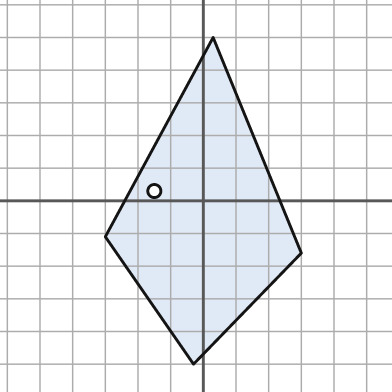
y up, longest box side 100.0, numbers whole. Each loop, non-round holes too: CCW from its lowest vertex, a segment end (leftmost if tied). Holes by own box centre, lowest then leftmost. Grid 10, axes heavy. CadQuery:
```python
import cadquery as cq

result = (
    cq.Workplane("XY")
    .moveTo(-3.0, -50.0)
    .lineTo(30.0, -16.0)
    .lineTo(3.0, 50.0)
    .lineTo(-30.0, -11.0)
    .close()
    .moveTo(-15.0, 3.0)
    .circle(2.0)
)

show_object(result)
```